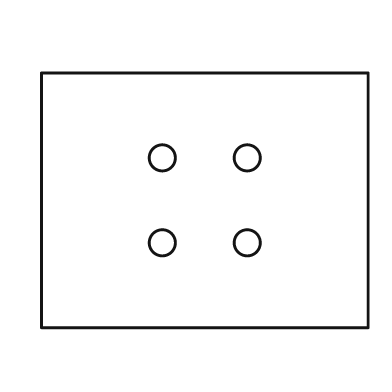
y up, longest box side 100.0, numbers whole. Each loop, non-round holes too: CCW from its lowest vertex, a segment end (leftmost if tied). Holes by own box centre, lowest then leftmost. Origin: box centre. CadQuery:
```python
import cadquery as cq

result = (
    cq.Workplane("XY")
    .moveTo(-50.0, -39.0)
    .lineTo(50.0, -39.0)
    .lineTo(50.0, 39.0)
    .lineTo(-50.0, 39.0)
    .close()
    .moveTo(-13.0, -13.0)
    .circle(4.0)
    .moveTo(13.0, -13.0)
    .circle(4.0)
    .moveTo(-13.0, 13.0)
    .circle(4.0)
    .moveTo(13.0, 13.0)
    .circle(4.0)
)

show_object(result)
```